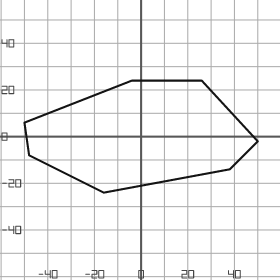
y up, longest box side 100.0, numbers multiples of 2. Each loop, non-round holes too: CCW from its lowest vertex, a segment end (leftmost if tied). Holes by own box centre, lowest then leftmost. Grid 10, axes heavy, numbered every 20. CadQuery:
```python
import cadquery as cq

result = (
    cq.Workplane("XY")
    .moveTo(-16.0, -24.0)
    .lineTo(38.0, -14.0)
    .lineTo(50.0, -2.0)
    .lineTo(26.0, 24.0)
    .lineTo(-4.0, 24.0)
    .lineTo(-50.0, 6.0)
    .lineTo(-48.0, -8.0)
    .close()
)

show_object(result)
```